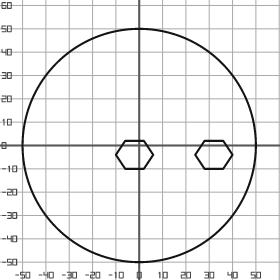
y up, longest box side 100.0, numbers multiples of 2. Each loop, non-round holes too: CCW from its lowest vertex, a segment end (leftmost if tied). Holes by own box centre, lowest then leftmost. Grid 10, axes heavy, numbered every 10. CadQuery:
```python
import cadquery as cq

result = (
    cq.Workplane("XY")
    .moveTo(0.0, 0.0)
    .circle(50.0)
    .moveTo(-6.0, -10.0)
    .lineTo(2.0, -10.0)
    .lineTo(6.0, -4.0)
    .lineTo(2.0, 2.0)
    .lineTo(-6.0, 2.0)
    .lineTo(-10.0, -4.0)
    .close()
    .moveTo(28.0, -10.0)
    .lineTo(36.0, -10.0)
    .lineTo(40.0, -4.0)
    .lineTo(36.0, 2.0)
    .lineTo(28.0, 2.0)
    .lineTo(24.0, -4.0)
    .close()
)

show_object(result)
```